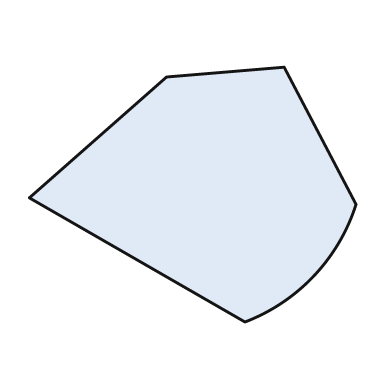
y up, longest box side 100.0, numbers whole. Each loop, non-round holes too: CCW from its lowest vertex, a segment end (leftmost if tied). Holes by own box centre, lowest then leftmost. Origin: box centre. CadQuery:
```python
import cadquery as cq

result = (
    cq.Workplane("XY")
    .moveTo(16.0, -39.0)
    .threePointArc((37.0, -25.0), (50.0, -3.0))
    .lineTo(28.0, 39.0)
    .lineTo(-8.0, 36.0)
    .lineTo(-50.0, -1.0)
    .close()
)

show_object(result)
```